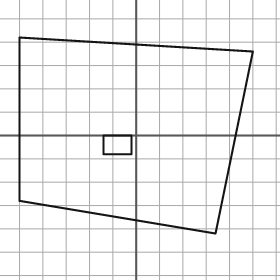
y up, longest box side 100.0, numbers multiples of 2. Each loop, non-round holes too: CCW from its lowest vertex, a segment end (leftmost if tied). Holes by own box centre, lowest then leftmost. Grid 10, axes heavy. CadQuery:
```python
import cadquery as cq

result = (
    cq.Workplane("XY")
    .moveTo(34.0, -42.0)
    .lineTo(50.0, 36.0)
    .lineTo(-50.0, 42.0)
    .lineTo(-50.0, -28.0)
    .close()
    .moveTo(-14.0, -8.0)
    .lineTo(-2.0, -8.0)
    .lineTo(-2.0, 0.0)
    .lineTo(-14.0, 0.0)
    .close()
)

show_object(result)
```